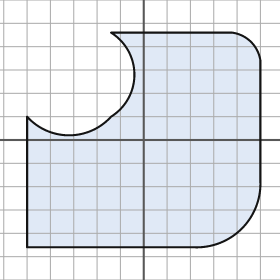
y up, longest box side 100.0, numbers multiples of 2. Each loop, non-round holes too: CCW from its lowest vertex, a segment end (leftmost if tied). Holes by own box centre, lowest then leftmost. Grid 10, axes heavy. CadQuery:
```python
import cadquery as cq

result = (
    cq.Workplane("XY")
    .moveTo(-50.0, -46.0)
    .lineTo(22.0, -46.0)
    .threePointArc((42.0, -38.0), (50.0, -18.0))
    .lineTo(50.0, 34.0)
    .threePointArc((46.0, 42.0), (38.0, 46.0))
    .lineTo(-14.0, 46.0)
    .threePointArc((-4.0, 28.0), (-14.0, 10.0))
    .threePointArc((-32.0, 2.0), (-50.0, 10.0))
    .close()
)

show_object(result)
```